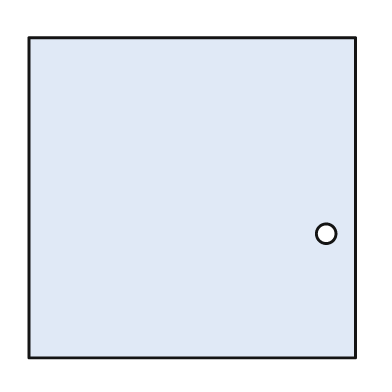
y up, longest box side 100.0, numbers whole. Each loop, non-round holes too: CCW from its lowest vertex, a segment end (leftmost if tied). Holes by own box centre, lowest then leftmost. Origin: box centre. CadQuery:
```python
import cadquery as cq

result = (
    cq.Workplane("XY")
    .moveTo(-50.0, -49.0)
    .lineTo(50.0, -49.0)
    .lineTo(50.0, 49.0)
    .lineTo(-50.0, 49.0)
    .close()
    .moveTo(41.0, -11.0)
    .circle(3.0)
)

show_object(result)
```